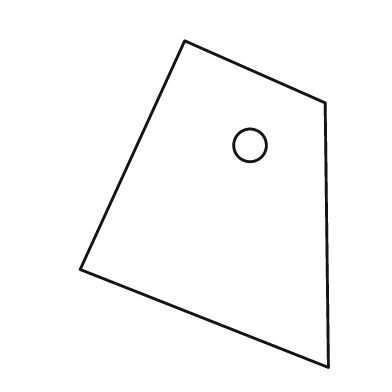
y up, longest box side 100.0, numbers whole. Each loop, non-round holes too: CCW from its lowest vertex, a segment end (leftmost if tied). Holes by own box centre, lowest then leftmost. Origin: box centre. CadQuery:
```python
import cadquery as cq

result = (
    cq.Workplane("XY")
    .moveTo(38.0, -50.0)
    .lineTo(37.0, 31.0)
    .lineTo(-6.0, 50.0)
    .lineTo(-38.0, -20.0)
    .close()
    .moveTo(14.0, 18.0)
    .circle(5.0)
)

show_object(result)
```